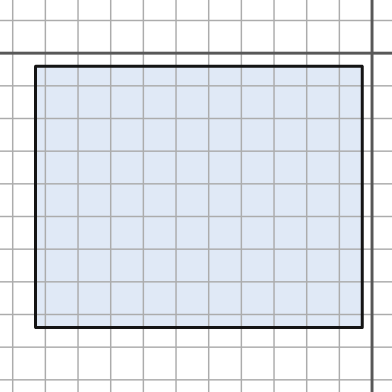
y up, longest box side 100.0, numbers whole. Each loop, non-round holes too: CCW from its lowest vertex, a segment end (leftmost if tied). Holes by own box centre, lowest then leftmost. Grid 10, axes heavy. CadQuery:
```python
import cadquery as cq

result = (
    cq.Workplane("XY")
    .moveTo(-103.0, -84.0)
    .lineTo(-3.0, -84.0)
    .lineTo(-3.0, -4.0)
    .lineTo(-103.0, -4.0)
    .close()
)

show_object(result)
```